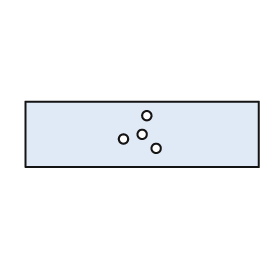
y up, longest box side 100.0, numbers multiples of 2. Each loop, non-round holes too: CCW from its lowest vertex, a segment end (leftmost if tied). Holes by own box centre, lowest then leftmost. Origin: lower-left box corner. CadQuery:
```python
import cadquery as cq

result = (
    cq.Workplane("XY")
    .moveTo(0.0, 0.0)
    .lineTo(100.0, 0.0)
    .lineTo(100.0, 28.0)
    .lineTo(0.0, 28.0)
    .close()
    .moveTo(56.0, 8.0)
    .circle(2.0)
    .moveTo(42.0, 12.0)
    .circle(2.0)
    .moveTo(50.0, 14.0)
    .circle(2.0)
    .moveTo(52.0, 22.0)
    .circle(2.0)
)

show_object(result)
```